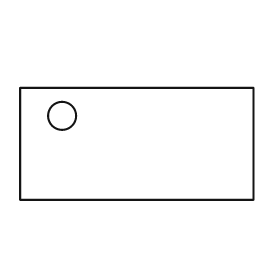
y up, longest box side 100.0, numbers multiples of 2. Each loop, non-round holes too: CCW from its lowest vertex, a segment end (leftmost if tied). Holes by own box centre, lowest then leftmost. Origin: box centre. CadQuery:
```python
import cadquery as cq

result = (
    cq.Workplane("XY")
    .moveTo(-50.0, -24.0)
    .lineTo(50.0, -24.0)
    .lineTo(50.0, 24.0)
    .lineTo(-50.0, 24.0)
    .close()
    .moveTo(-32.0, 12.0)
    .circle(6.0)
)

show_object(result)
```